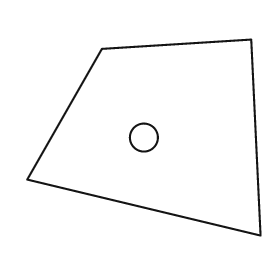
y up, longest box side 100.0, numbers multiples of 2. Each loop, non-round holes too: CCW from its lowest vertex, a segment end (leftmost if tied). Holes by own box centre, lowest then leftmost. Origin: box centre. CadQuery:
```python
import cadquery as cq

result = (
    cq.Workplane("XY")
    .moveTo(50.0, -42.0)
    .lineTo(46.0, 42.0)
    .lineTo(-18.0, 38.0)
    .lineTo(-50.0, -18.0)
    .close()
    .moveTo(0.0, 0.0)
    .circle(6.0)
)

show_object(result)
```